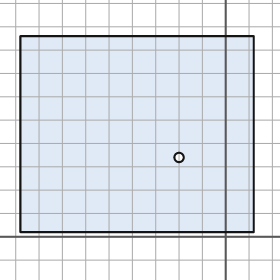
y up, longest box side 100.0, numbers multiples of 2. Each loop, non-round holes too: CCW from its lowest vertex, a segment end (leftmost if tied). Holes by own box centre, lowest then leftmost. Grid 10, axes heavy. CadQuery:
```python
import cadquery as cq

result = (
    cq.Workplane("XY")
    .moveTo(-88.0, 2.0)
    .lineTo(12.0, 2.0)
    .lineTo(12.0, 86.0)
    .lineTo(-88.0, 86.0)
    .close()
    .moveTo(-20.0, 34.0)
    .circle(2.0)
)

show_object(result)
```